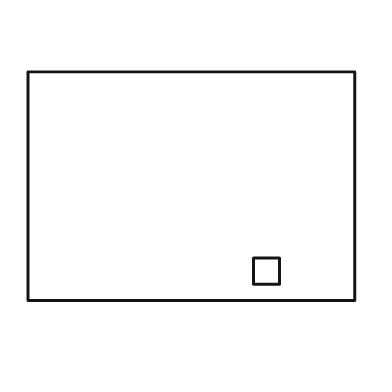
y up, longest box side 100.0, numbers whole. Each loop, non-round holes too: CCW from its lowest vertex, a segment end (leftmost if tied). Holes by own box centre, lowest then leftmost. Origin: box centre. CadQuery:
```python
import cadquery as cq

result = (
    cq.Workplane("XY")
    .moveTo(-50.0, -35.0)
    .lineTo(50.0, -35.0)
    .lineTo(50.0, 35.0)
    .lineTo(-50.0, 35.0)
    .close()
    .moveTo(19.0, -30.0)
    .lineTo(27.0, -30.0)
    .lineTo(27.0, -22.0)
    .lineTo(19.0, -22.0)
    .close()
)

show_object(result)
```